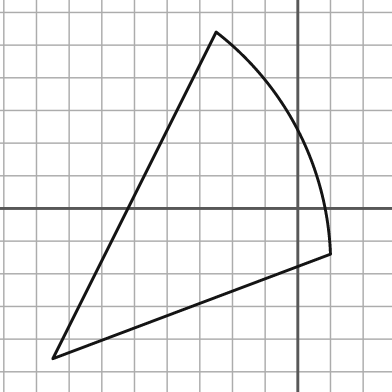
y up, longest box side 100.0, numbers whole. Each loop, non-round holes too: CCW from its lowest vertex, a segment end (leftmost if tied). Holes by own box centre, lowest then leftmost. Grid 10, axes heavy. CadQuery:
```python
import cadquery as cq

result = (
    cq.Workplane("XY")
    .moveTo(-75.0, -46.0)
    .lineTo(10.0, -14.0)
    .threePointArc((0.0, 24.0), (-25.0, 54.0))
    .close()
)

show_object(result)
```